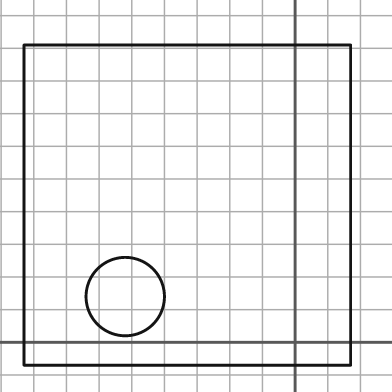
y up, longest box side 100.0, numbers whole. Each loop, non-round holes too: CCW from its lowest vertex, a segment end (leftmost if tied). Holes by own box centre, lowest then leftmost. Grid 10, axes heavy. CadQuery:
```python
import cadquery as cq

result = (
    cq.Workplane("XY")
    .moveTo(-83.0, -7.0)
    .lineTo(17.0, -7.0)
    .lineTo(17.0, 91.0)
    .lineTo(-83.0, 91.0)
    .close()
    .moveTo(-52.0, 14.0)
    .circle(12.0)
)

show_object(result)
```